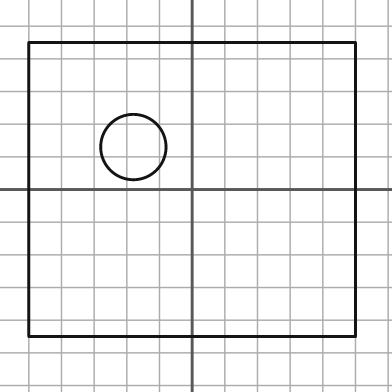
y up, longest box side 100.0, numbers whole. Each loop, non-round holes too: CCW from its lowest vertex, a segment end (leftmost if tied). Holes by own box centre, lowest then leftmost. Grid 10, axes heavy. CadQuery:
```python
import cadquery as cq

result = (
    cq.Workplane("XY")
    .moveTo(-50.0, -45.0)
    .lineTo(50.0, -45.0)
    .lineTo(50.0, 45.0)
    .lineTo(-50.0, 45.0)
    .close()
    .moveTo(-18.0, 13.0)
    .circle(10.0)
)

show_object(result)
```